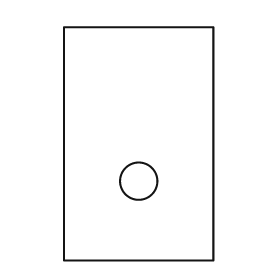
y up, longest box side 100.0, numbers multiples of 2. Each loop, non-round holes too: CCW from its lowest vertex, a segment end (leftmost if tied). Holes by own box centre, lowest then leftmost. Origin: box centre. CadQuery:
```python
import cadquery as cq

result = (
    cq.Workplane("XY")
    .moveTo(-32.0, -50.0)
    .lineTo(32.0, -50.0)
    .lineTo(32.0, 50.0)
    .lineTo(-32.0, 50.0)
    .close()
    .moveTo(0.0, -16.0)
    .circle(8.0)
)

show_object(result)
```